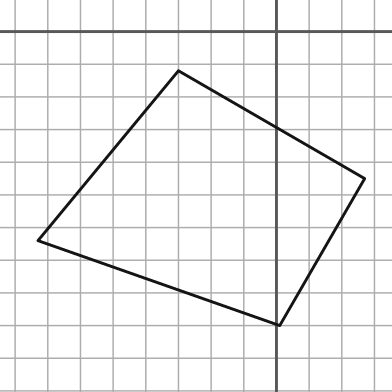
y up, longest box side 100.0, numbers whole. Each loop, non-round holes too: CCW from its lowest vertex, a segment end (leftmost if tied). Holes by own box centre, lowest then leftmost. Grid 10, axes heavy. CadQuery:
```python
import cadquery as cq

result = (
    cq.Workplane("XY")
    .moveTo(1.0, -90.0)
    .lineTo(27.0, -45.0)
    .lineTo(-30.0, -12.0)
    .lineTo(-73.0, -64.0)
    .close()
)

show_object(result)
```